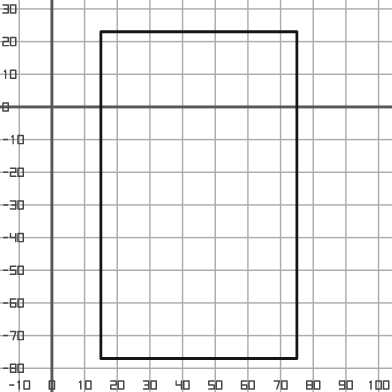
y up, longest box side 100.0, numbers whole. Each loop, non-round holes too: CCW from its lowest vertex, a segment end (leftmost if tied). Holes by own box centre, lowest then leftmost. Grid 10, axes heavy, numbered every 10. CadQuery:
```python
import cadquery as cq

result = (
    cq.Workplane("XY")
    .moveTo(15.0, -77.0)
    .lineTo(75.0, -77.0)
    .lineTo(75.0, 23.0)
    .lineTo(15.0, 23.0)
    .close()
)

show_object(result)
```